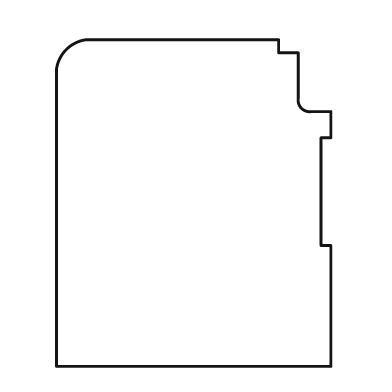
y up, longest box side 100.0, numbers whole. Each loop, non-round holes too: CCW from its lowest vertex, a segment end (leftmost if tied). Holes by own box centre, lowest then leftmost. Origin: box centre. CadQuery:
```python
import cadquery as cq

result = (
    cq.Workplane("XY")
    .moveTo(-42.0, -50.0)
    .lineTo(42.0, -50.0)
    .lineTo(42.0, -13.0)
    .lineTo(39.0, -13.0)
    .lineTo(39.0, 20.0)
    .lineTo(42.0, 20.0)
    .lineTo(42.0, 28.0)
    .lineTo(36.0, 28.0)
    .threePointArc((33.0, 29.0), (32.0, 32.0))
    .lineTo(32.0, 46.0)
    .lineTo(26.0, 46.0)
    .lineTo(26.0, 50.0)
    .lineTo(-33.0, 50.0)
    .threePointArc((-39.0, 47.0), (-42.0, 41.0))
    .close()
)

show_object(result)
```